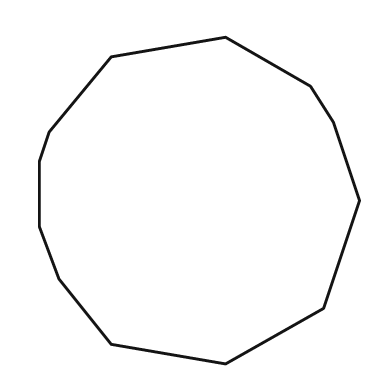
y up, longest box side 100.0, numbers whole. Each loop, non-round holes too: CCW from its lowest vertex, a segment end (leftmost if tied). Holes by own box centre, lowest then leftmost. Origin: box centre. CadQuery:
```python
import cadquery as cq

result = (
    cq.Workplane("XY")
    .moveTo(8.0, -50.0)
    .lineTo(38.0, -33.0)
    .lineTo(49.0, 0.0)
    .lineTo(41.0, 24.0)
    .lineTo(34.0, 35.0)
    .lineTo(8.0, 50.0)
    .lineTo(-27.0, 44.0)
    .lineTo(-46.0, 21.0)
    .lineTo(-49.0, 12.0)
    .lineTo(-49.0, -8.0)
    .lineTo(-43.0, -24.0)
    .lineTo(-27.0, -44.0)
    .close()
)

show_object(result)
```